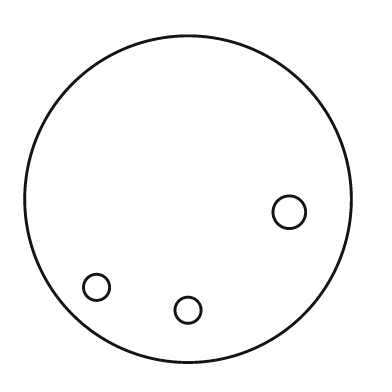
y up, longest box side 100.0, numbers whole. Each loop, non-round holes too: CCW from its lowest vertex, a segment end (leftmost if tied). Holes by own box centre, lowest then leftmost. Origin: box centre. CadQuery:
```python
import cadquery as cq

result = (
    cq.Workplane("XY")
    .moveTo(0.0, 0.0)
    .circle(50.0)
    .moveTo(0.0, -34.0)
    .circle(4.0)
    .moveTo(-28.0, -27.0)
    .circle(4.0)
    .moveTo(31.0, -4.0)
    .circle(5.0)
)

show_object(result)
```